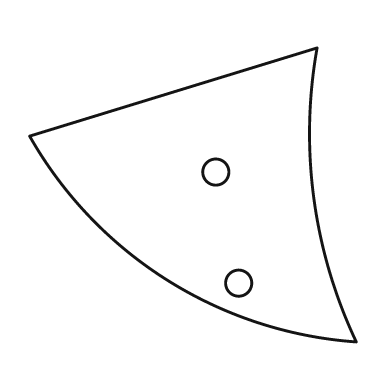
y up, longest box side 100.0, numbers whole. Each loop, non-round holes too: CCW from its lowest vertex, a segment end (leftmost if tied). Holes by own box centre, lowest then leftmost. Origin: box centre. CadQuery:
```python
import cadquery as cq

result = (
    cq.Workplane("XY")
    .moveTo(50.0, -45.0)
    .threePointArc((37.0, -1.0), (38.0, 45.0))
    .lineTo(-50.0, 18.0)
    .threePointArc((-8.0, -26.0), (50.0, -45.0))
    .close()
    .moveTo(14.0, -27.0)
    .circle(4.0)
    .moveTo(7.0, 7.0)
    .circle(4.0)
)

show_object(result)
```